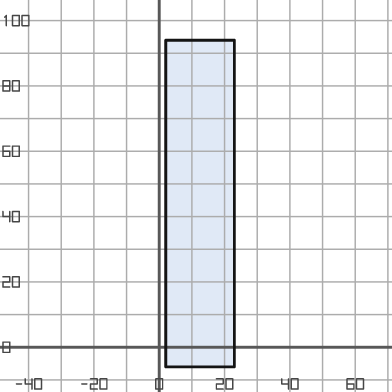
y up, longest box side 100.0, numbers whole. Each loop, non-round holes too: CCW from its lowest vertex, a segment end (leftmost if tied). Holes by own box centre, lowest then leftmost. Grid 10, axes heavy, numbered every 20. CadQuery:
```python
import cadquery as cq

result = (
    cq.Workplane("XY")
    .moveTo(2.0, -6.0)
    .lineTo(23.0, -6.0)
    .lineTo(23.0, 94.0)
    .lineTo(2.0, 94.0)
    .close()
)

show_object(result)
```